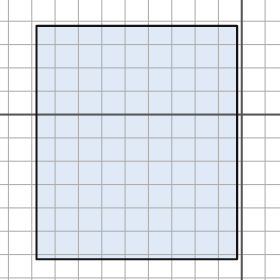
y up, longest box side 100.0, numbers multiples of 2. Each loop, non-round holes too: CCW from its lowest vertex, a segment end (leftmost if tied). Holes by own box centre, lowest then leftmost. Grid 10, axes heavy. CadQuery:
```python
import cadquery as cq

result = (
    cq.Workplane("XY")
    .moveTo(-88.0, -62.0)
    .lineTo(-2.0, -62.0)
    .lineTo(-2.0, 38.0)
    .lineTo(-88.0, 38.0)
    .close()
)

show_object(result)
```